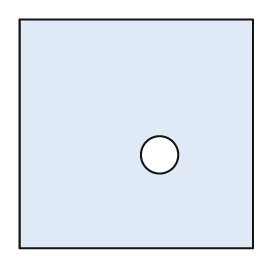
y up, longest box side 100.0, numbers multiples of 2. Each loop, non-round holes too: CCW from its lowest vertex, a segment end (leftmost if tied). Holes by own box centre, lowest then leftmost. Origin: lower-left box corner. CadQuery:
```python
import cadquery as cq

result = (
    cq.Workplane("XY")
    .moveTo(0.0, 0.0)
    .lineTo(100.0, 0.0)
    .lineTo(100.0, 98.0)
    .lineTo(0.0, 98.0)
    .close()
    .moveTo(60.0, 40.0)
    .circle(8.0)
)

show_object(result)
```